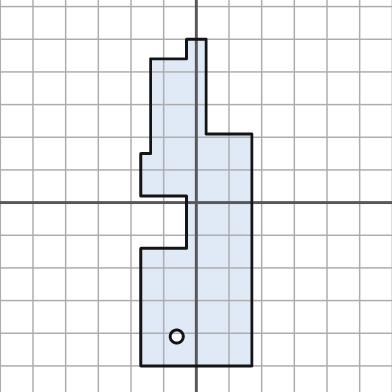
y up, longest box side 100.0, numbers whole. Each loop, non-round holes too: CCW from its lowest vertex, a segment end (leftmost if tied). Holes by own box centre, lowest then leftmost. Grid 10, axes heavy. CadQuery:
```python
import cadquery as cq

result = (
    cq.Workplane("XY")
    .moveTo(-17.0, -50.0)
    .lineTo(17.0, -50.0)
    .lineTo(17.0, 21.0)
    .lineTo(3.0, 21.0)
    .lineTo(3.0, 50.0)
    .lineTo(-3.0, 50.0)
    .lineTo(-3.0, 44.0)
    .lineTo(-14.0, 44.0)
    .lineTo(-14.0, 15.0)
    .lineTo(-17.0, 15.0)
    .lineTo(-17.0, 2.0)
    .lineTo(-3.0, 2.0)
    .lineTo(-3.0, -14.0)
    .lineTo(-17.0, -14.0)
    .close()
    .moveTo(-6.0, -41.0)
    .circle(2.0)
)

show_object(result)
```